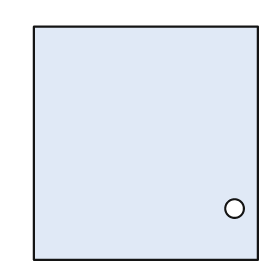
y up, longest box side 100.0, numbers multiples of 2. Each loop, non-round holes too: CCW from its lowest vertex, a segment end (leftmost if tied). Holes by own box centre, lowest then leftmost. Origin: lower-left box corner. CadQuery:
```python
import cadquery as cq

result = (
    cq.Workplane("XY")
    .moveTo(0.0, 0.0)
    .lineTo(96.0, 0.0)
    .lineTo(96.0, 100.0)
    .lineTo(0.0, 100.0)
    .close()
    .moveTo(86.0, 22.0)
    .circle(4.0)
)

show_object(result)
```